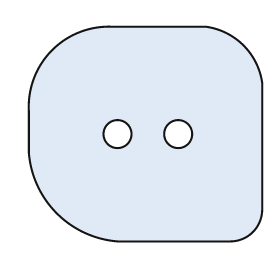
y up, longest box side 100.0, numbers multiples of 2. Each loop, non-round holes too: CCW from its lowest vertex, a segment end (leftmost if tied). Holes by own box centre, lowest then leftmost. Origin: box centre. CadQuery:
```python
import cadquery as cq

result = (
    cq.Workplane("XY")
    .moveTo(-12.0, -46.0)
    .lineTo(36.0, -46.0)
    .threePointArc((46.0, -42.0), (50.0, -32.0))
    .lineTo(50.0, 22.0)
    .threePointArc((42.0, 38.0), (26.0, 46.0))
    .lineTo(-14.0, 46.0)
    .threePointArc((-40.0, 36.0), (-50.0, 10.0))
    .lineTo(-50.0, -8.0)
    .threePointArc((-38.0, -34.0), (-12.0, -46.0))
    .close()
    .moveTo(-12.0, 0.0)
    .circle(6.0)
    .moveTo(14.0, 0.0)
    .circle(6.0)
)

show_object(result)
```